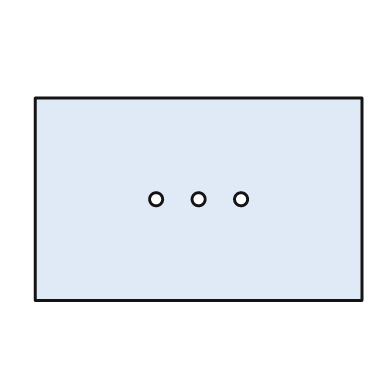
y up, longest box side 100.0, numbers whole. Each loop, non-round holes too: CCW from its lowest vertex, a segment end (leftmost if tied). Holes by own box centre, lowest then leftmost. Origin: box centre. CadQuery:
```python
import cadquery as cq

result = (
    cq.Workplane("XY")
    .moveTo(-50.0, -31.0)
    .lineTo(50.0, -31.0)
    .lineTo(50.0, 31.0)
    .lineTo(-50.0, 31.0)
    .close()
    .moveTo(-13.0, 0.0)
    .circle(2.0)
    .moveTo(0.0, 0.0)
    .circle(2.0)
    .moveTo(13.0, 0.0)
    .circle(2.0)
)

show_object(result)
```